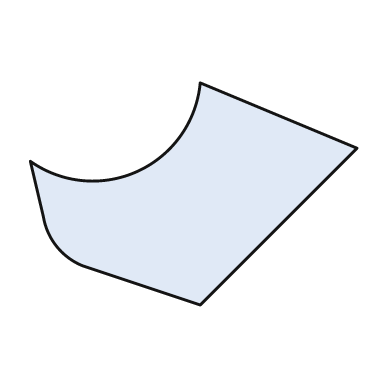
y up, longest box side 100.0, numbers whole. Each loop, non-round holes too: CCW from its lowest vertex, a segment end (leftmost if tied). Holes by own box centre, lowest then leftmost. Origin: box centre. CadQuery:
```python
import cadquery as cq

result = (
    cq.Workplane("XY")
    .moveTo(2.0, -34.0)
    .lineTo(50.0, 14.0)
    .lineTo(2.0, 34.0)
    .threePointArc((-17.0, 7.0), (-50.0, 10.0))
    .lineTo(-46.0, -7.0)
    .threePointArc((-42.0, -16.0), (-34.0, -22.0))
    .close()
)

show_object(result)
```